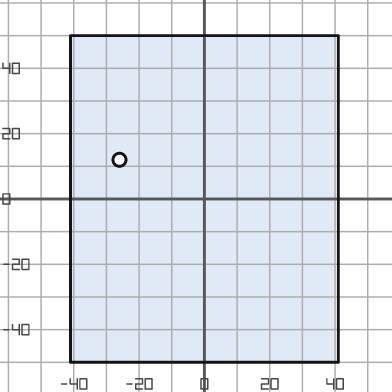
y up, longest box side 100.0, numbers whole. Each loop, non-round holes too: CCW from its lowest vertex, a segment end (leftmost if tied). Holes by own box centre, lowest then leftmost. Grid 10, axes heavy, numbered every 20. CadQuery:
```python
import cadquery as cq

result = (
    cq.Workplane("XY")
    .moveTo(-41.0, -50.0)
    .lineTo(41.0, -50.0)
    .lineTo(41.0, 50.0)
    .lineTo(-41.0, 50.0)
    .close()
    .moveTo(-26.0, 12.0)
    .circle(2.0)
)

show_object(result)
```